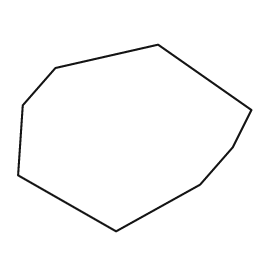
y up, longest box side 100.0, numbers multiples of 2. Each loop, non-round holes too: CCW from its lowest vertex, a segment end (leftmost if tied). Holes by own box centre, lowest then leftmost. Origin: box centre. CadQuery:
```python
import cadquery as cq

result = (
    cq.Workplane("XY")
    .moveTo(-8.0, -40.0)
    .lineTo(28.0, -20.0)
    .lineTo(42.0, -4.0)
    .lineTo(50.0, 12.0)
    .lineTo(10.0, 40.0)
    .lineTo(-34.0, 30.0)
    .lineTo(-48.0, 14.0)
    .lineTo(-50.0, -16.0)
    .close()
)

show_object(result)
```